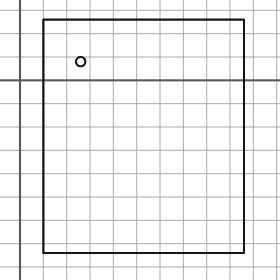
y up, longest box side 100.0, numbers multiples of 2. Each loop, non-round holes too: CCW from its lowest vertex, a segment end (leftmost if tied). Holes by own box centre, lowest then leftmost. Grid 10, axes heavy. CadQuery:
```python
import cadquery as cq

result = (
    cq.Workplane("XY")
    .moveTo(10.0, -74.0)
    .lineTo(96.0, -74.0)
    .lineTo(96.0, 26.0)
    .lineTo(10.0, 26.0)
    .close()
    .moveTo(26.0, 8.0)
    .circle(2.0)
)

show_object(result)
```